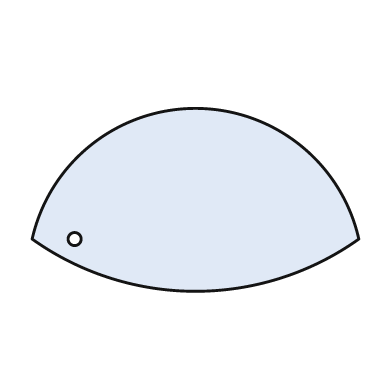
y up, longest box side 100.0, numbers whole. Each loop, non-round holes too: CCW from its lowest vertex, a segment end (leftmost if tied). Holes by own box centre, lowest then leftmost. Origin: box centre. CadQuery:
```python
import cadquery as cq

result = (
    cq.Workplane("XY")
    .moveTo(-50.0, -12.0)
    .threePointArc((0.0, -28.0), (50.0, -12.0))
    .threePointArc((0.0, 28.0), (-50.0, -12.0))
    .close()
    .moveTo(-37.0, -12.0)
    .circle(2.0)
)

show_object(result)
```